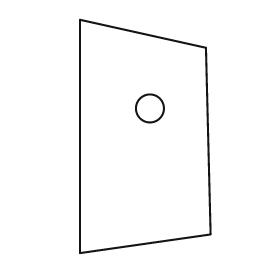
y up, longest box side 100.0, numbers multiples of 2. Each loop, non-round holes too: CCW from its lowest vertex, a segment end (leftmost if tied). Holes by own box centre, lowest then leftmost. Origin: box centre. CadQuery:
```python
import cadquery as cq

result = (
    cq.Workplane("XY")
    .moveTo(-28.0, -50.0)
    .lineTo(28.0, -42.0)
    .lineTo(26.0, 38.0)
    .lineTo(-28.0, 50.0)
    .close()
    .moveTo(2.0, 12.0)
    .circle(6.0)
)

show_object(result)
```